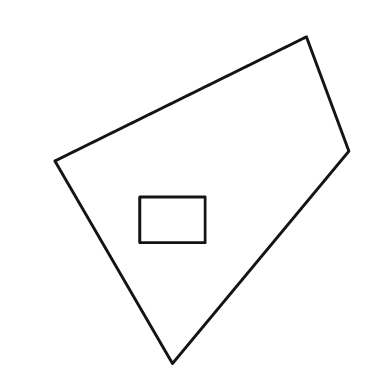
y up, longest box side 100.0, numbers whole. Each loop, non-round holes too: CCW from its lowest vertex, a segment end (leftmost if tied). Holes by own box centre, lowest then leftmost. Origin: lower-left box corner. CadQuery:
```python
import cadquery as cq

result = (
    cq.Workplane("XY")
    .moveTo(36.0, 0.0)
    .lineTo(90.0, 65.0)
    .lineTo(77.0, 100.0)
    .lineTo(0.0, 62.0)
    .close()
    .moveTo(26.0, 37.0)
    .lineTo(46.0, 37.0)
    .lineTo(46.0, 51.0)
    .lineTo(26.0, 51.0)
    .close()
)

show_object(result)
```